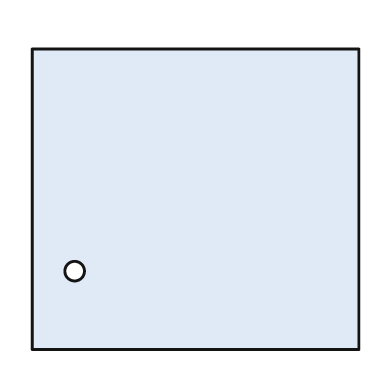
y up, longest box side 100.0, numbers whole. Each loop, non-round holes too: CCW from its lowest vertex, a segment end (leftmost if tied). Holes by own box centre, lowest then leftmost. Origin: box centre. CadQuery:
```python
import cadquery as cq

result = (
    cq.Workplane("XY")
    .moveTo(-50.0, -46.0)
    .lineTo(50.0, -46.0)
    .lineTo(50.0, 46.0)
    .lineTo(-50.0, 46.0)
    .close()
    .moveTo(-37.0, -22.0)
    .circle(3.0)
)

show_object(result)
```